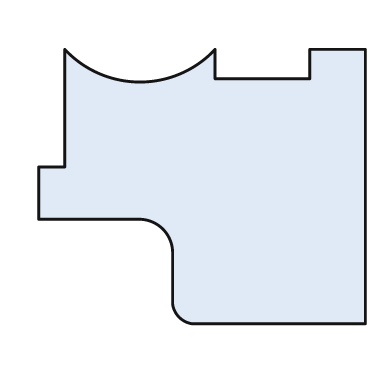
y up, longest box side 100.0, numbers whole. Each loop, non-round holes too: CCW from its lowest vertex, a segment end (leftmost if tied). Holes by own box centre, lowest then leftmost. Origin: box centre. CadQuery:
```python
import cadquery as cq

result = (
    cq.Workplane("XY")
    .moveTo(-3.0, -42.0)
    .lineTo(50.0, -42.0)
    .lineTo(50.0, 42.0)
    .lineTo(33.0, 42.0)
    .lineTo(33.0, 33.0)
    .lineTo(4.0, 33.0)
    .lineTo(4.0, 42.0)
    .threePointArc((-19.0, 32.0), (-42.0, 42.0))
    .lineTo(-42.0, 6.0)
    .lineTo(-50.0, 6.0)
    .lineTo(-50.0, -10.0)
    .lineTo(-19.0, -10.0)
    .threePointArc((-12.0, -13.0), (-9.0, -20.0))
    .lineTo(-9.0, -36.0)
    .threePointArc((-7.0, -40.0), (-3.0, -42.0))
    .close()
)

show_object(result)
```